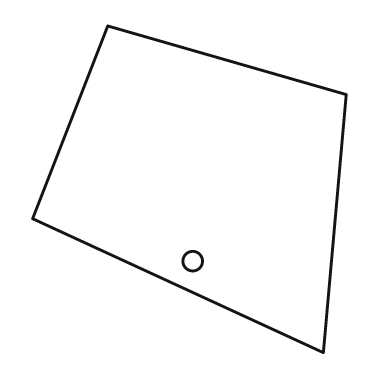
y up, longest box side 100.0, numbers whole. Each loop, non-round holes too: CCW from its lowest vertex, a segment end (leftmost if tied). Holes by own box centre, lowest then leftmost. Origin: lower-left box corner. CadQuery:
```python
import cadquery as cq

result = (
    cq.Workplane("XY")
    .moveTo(89.0, 0.0)
    .lineTo(96.0, 79.0)
    .lineTo(23.0, 100.0)
    .lineTo(0.0, 41.0)
    .close()
    .moveTo(49.0, 28.0)
    .circle(3.0)
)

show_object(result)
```